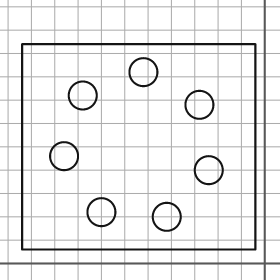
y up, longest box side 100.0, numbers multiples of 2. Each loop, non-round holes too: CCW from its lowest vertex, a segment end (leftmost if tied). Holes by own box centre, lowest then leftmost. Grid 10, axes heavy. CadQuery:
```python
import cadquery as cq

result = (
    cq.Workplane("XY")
    .moveTo(-104.0, 6.0)
    .lineTo(-4.0, 6.0)
    .lineTo(-4.0, 94.0)
    .lineTo(-104.0, 94.0)
    .close()
    .moveTo(-42.0, 20.0)
    .circle(6.0)
    .moveTo(-70.0, 22.0)
    .circle(6.0)
    .moveTo(-24.0, 40.0)
    .circle(6.0)
    .moveTo(-86.0, 46.0)
    .circle(6.0)
    .moveTo(-28.0, 68.0)
    .circle(6.0)
    .moveTo(-78.0, 72.0)
    .circle(6.0)
    .moveTo(-52.0, 82.0)
    .circle(6.0)
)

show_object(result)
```